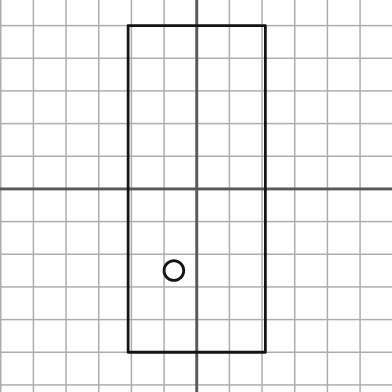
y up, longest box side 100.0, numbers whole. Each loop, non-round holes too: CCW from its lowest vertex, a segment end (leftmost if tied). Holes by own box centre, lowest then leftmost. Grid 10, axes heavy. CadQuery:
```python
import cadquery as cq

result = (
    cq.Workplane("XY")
    .moveTo(-21.0, -50.0)
    .lineTo(21.0, -50.0)
    .lineTo(21.0, 50.0)
    .lineTo(-21.0, 50.0)
    .close()
    .moveTo(-7.0, -25.0)
    .circle(3.0)
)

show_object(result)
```